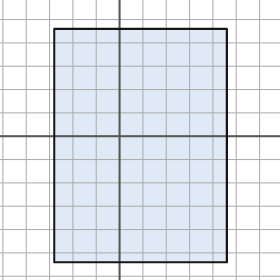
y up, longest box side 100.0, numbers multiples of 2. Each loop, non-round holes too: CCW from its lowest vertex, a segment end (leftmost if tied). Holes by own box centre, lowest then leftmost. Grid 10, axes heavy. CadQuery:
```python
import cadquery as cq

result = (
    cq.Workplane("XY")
    .moveTo(-28.0, -54.0)
    .lineTo(46.0, -54.0)
    .lineTo(46.0, 46.0)
    .lineTo(-28.0, 46.0)
    .close()
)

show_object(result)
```